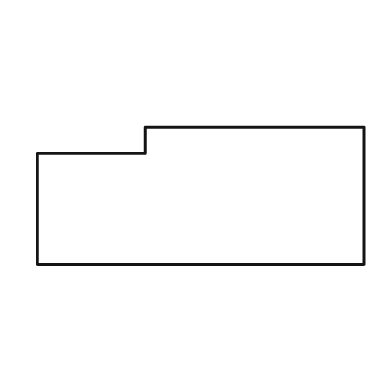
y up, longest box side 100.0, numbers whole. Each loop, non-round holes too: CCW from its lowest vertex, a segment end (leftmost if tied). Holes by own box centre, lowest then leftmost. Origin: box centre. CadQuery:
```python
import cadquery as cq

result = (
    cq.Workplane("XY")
    .moveTo(-50.0, -21.0)
    .lineTo(50.0, -21.0)
    .lineTo(50.0, 21.0)
    .lineTo(-17.0, 21.0)
    .lineTo(-17.0, 13.0)
    .lineTo(-50.0, 13.0)
    .close()
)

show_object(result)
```